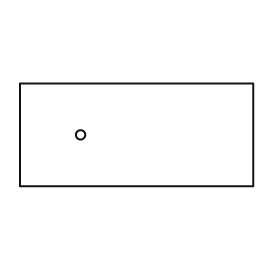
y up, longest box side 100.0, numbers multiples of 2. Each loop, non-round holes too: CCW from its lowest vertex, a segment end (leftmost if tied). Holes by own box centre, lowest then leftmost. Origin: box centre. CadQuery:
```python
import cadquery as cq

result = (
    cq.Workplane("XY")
    .moveTo(-50.0, -22.0)
    .lineTo(50.0, -22.0)
    .lineTo(50.0, 22.0)
    .lineTo(-50.0, 22.0)
    .close()
    .moveTo(-24.0, 0.0)
    .circle(2.0)
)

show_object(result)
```